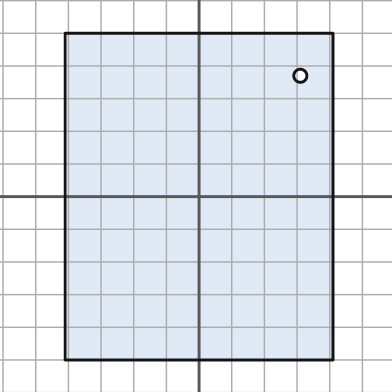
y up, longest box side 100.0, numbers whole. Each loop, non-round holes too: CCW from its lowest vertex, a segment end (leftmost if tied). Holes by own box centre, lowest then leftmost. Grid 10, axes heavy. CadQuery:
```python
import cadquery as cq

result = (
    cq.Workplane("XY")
    .moveTo(-41.0, -50.0)
    .lineTo(41.0, -50.0)
    .lineTo(41.0, 50.0)
    .lineTo(-41.0, 50.0)
    .close()
    .moveTo(31.0, 37.0)
    .circle(2.0)
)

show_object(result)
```